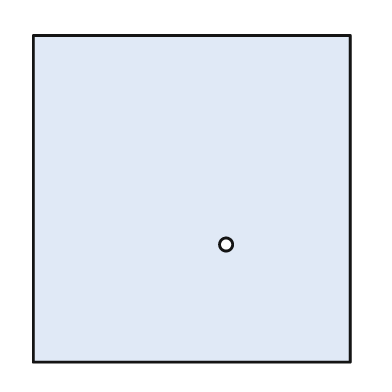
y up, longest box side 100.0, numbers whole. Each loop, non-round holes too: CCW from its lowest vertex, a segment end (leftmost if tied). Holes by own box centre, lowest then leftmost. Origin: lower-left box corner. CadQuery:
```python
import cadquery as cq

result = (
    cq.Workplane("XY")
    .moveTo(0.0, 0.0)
    .lineTo(97.0, 0.0)
    .lineTo(97.0, 100.0)
    .lineTo(0.0, 100.0)
    .close()
    .moveTo(59.0, 36.0)
    .circle(2.0)
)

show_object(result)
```